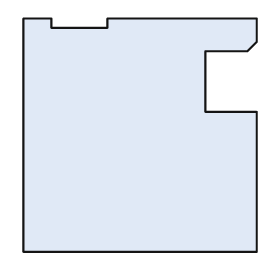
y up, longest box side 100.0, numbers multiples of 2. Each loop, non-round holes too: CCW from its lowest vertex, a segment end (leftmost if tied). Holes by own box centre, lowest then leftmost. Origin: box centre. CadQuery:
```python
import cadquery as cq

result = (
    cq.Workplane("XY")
    .moveTo(-50.0, -50.0)
    .lineTo(50.0, -50.0)
    .lineTo(50.0, 10.0)
    .lineTo(28.0, 10.0)
    .lineTo(28.0, 36.0)
    .lineTo(46.0, 36.0)
    .lineTo(50.0, 40.0)
    .lineTo(50.0, 50.0)
    .lineTo(-14.0, 50.0)
    .lineTo(-14.0, 46.0)
    .lineTo(-38.0, 46.0)
    .lineTo(-38.0, 50.0)
    .lineTo(-50.0, 50.0)
    .close()
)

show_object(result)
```